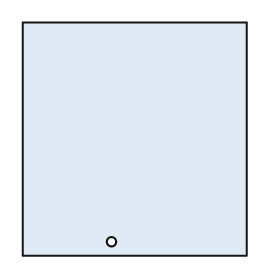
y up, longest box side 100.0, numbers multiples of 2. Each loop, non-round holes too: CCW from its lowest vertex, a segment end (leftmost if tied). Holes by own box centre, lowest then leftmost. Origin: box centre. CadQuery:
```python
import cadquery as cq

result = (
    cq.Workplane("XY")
    .moveTo(-48.0, -50.0)
    .lineTo(48.0, -50.0)
    .lineTo(48.0, 50.0)
    .lineTo(-48.0, 50.0)
    .close()
    .moveTo(-10.0, -44.0)
    .circle(2.0)
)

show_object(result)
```